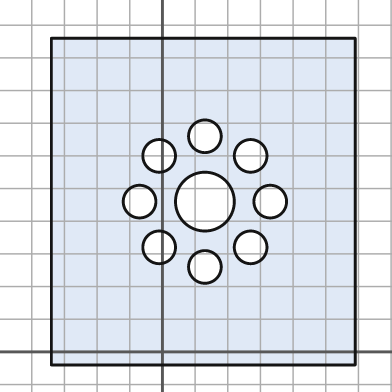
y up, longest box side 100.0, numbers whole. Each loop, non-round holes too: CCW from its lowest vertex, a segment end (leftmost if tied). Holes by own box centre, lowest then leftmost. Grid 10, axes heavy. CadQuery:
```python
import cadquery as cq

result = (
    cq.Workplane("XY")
    .moveTo(-34.0, -4.0)
    .lineTo(59.0, -4.0)
    .lineTo(59.0, 96.0)
    .lineTo(-34.0, 96.0)
    .close()
    .moveTo(13.0, 26.0)
    .circle(5.0)
    .moveTo(-1.0, 32.0)
    .circle(5.0)
    .moveTo(27.0, 32.0)
    .circle(5.0)
    .moveTo(-7.0, 46.0)
    .circle(5.0)
    .moveTo(13.0, 46.0)
    .circle(9.0)
    .moveTo(33.0, 46.0)
    .circle(5.0)
    .moveTo(-1.0, 60.0)
    .circle(5.0)
    .moveTo(27.0, 60.0)
    .circle(5.0)
    .moveTo(13.0, 66.0)
    .circle(5.0)
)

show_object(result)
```